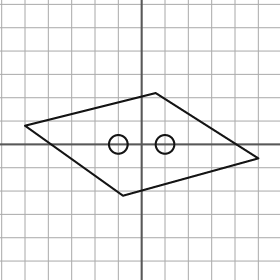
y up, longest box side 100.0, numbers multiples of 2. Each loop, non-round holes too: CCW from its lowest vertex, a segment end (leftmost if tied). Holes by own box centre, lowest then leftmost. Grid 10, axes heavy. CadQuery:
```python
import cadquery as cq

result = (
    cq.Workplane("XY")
    .moveTo(-8.0, -22.0)
    .lineTo(50.0, -6.0)
    .lineTo(6.0, 22.0)
    .lineTo(-50.0, 8.0)
    .close()
    .moveTo(-10.0, 0.0)
    .circle(4.0)
    .moveTo(10.0, 0.0)
    .circle(4.0)
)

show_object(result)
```